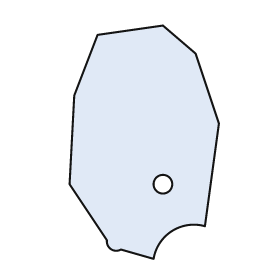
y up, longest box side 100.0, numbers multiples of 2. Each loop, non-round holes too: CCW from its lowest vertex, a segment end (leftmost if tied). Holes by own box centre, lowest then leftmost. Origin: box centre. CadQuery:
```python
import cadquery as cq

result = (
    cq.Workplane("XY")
    .moveTo(4.0, -50.0)
    .threePointArc((12.0, -38.0), (26.0, -36.0))
    .lineTo(32.0, 8.0)
    .lineTo(22.0, 38.0)
    .lineTo(8.0, 50.0)
    .lineTo(-20.0, 46.0)
    .lineTo(-30.0, 20.0)
    .lineTo(-32.0, -18.0)
    .lineTo(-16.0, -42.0)
    .threePointArc((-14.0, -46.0), (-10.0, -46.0))
    .close()
    .moveTo(8.0, -18.0)
    .circle(4.0)
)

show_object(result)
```